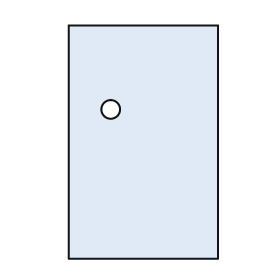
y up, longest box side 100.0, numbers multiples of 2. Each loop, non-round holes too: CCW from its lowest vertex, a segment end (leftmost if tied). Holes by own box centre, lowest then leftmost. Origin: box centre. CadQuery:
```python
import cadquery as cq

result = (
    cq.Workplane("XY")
    .moveTo(-32.0, -50.0)
    .lineTo(32.0, -50.0)
    .lineTo(32.0, 50.0)
    .lineTo(-32.0, 50.0)
    .close()
    .moveTo(-14.0, 14.0)
    .circle(4.0)
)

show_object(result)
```